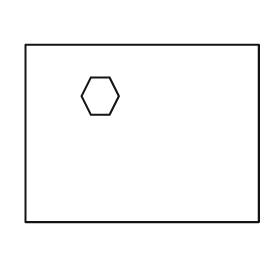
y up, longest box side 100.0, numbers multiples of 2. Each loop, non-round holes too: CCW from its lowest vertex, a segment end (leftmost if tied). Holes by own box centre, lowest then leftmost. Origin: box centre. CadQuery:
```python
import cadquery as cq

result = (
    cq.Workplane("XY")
    .moveTo(-50.0, -38.0)
    .lineTo(50.0, -38.0)
    .lineTo(50.0, 38.0)
    .lineTo(-50.0, 38.0)
    .close()
    .moveTo(-22.0, 8.0)
    .lineTo(-14.0, 8.0)
    .lineTo(-10.0, 16.0)
    .lineTo(-14.0, 24.0)
    .lineTo(-22.0, 24.0)
    .lineTo(-26.0, 16.0)
    .close()
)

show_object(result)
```